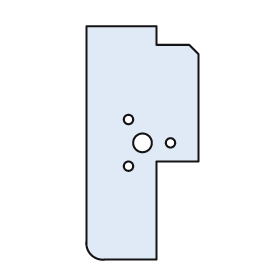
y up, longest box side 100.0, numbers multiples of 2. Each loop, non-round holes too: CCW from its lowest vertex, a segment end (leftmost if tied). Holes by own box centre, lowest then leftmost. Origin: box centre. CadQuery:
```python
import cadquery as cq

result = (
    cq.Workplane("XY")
    .moveTo(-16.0, -50.0)
    .lineTo(6.0, -50.0)
    .lineTo(6.0, -8.0)
    .lineTo(24.0, -8.0)
    .lineTo(24.0, 38.0)
    .lineTo(20.0, 42.0)
    .lineTo(6.0, 42.0)
    .lineTo(6.0, 50.0)
    .lineTo(-24.0, 50.0)
    .lineTo(-24.0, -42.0)
    .threePointArc((-22.0, -48.0), (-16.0, -50.0))
    .close()
    .moveTo(-6.0, -10.0)
    .circle(2.0)
    .moveTo(0.0, 0.0)
    .circle(4.0)
    .moveTo(12.0, 0.0)
    .circle(2.0)
    .moveTo(-6.0, 10.0)
    .circle(2.0)
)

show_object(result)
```